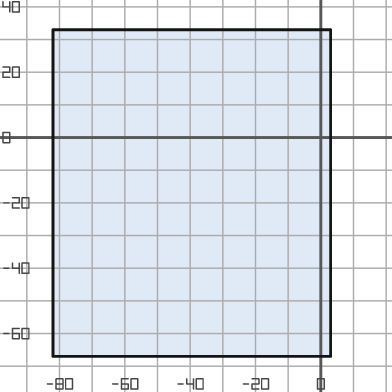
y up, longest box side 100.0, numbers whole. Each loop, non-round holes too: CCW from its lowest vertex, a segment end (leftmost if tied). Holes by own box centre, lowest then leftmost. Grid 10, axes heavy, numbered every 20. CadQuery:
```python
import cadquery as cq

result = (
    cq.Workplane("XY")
    .moveTo(-82.0, -67.0)
    .lineTo(3.0, -67.0)
    .lineTo(3.0, 33.0)
    .lineTo(-82.0, 33.0)
    .close()
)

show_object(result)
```